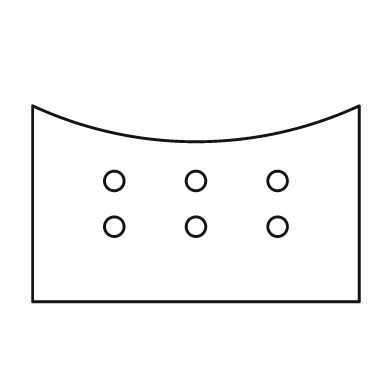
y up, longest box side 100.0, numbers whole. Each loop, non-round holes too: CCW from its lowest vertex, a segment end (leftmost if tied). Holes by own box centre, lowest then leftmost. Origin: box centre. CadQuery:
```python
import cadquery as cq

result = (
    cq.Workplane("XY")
    .moveTo(-50.0, -30.0)
    .lineTo(50.0, -30.0)
    .lineTo(50.0, 30.0)
    .threePointArc((0.0, 19.0), (-50.0, 30.0))
    .close()
    .moveTo(-25.0, -7.0)
    .circle(3.0)
    .moveTo(0.0, -7.0)
    .circle(3.0)
    .moveTo(25.0, -7.0)
    .circle(3.0)
    .moveTo(-25.0, 7.0)
    .circle(3.0)
    .moveTo(0.0, 7.0)
    .circle(3.0)
    .moveTo(25.0, 7.0)
    .circle(3.0)
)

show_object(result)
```